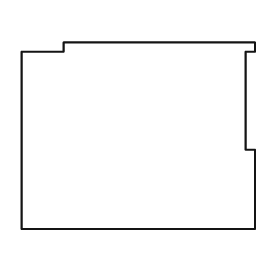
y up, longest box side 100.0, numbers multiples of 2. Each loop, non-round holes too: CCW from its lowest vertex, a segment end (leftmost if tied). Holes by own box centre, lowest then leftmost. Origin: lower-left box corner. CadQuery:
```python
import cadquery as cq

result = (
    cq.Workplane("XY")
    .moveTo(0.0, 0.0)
    .lineTo(100.0, 0.0)
    .lineTo(100.0, 34.0)
    .lineTo(96.0, 34.0)
    .lineTo(96.0, 76.0)
    .lineTo(100.0, 76.0)
    .lineTo(100.0, 80.0)
    .lineTo(18.0, 80.0)
    .lineTo(18.0, 76.0)
    .lineTo(0.0, 76.0)
    .close()
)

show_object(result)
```